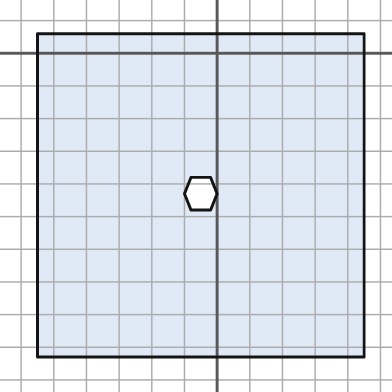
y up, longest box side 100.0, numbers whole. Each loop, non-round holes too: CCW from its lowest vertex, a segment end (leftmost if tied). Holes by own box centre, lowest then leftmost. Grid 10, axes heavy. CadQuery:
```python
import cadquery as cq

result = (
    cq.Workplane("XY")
    .moveTo(-55.0, -93.0)
    .lineTo(45.0, -93.0)
    .lineTo(45.0, 6.0)
    .lineTo(-55.0, 6.0)
    .close()
    .moveTo(-8.0, -48.0)
    .lineTo(-2.0, -48.0)
    .lineTo(0.0, -43.0)
    .lineTo(-2.0, -38.0)
    .lineTo(-8.0, -38.0)
    .lineTo(-10.0, -43.0)
    .close()
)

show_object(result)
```